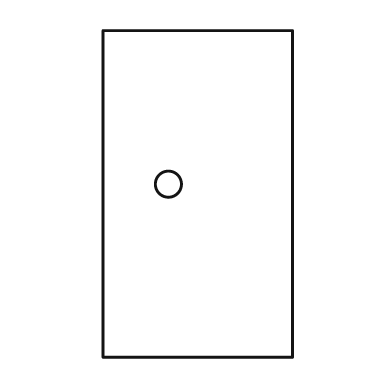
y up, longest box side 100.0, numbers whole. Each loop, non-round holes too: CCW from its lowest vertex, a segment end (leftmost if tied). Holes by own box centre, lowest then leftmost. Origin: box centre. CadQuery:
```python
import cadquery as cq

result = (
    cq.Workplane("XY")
    .moveTo(-29.0, -50.0)
    .lineTo(29.0, -50.0)
    .lineTo(29.0, 50.0)
    .lineTo(-29.0, 50.0)
    .close()
    .moveTo(-9.0, 3.0)
    .circle(4.0)
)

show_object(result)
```